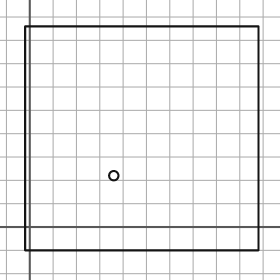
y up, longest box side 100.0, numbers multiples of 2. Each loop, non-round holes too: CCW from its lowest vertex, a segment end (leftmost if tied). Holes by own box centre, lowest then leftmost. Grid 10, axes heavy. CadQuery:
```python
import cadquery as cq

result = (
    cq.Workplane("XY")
    .moveTo(-2.0, -10.0)
    .lineTo(98.0, -10.0)
    .lineTo(98.0, 86.0)
    .lineTo(-2.0, 86.0)
    .close()
    .moveTo(36.0, 22.0)
    .circle(2.0)
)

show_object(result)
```